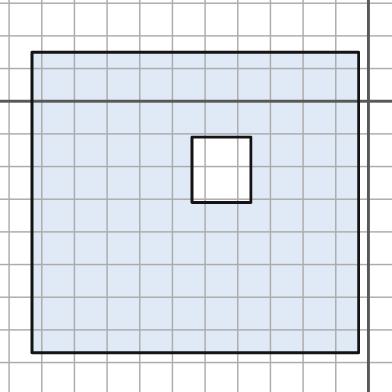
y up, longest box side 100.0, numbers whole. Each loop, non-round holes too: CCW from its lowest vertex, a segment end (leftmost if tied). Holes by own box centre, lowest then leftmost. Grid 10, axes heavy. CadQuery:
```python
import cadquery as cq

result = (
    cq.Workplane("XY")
    .moveTo(-103.0, -77.0)
    .lineTo(-3.0, -77.0)
    .lineTo(-3.0, 15.0)
    .lineTo(-103.0, 15.0)
    .close()
    .moveTo(-54.0, -31.0)
    .lineTo(-36.0, -31.0)
    .lineTo(-36.0, -11.0)
    .lineTo(-54.0, -11.0)
    .close()
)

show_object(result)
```